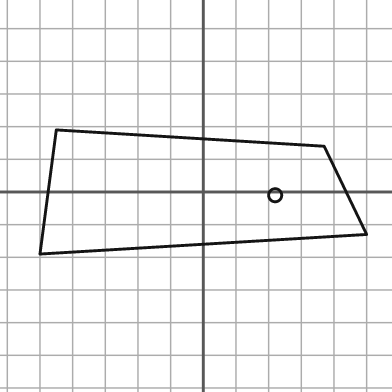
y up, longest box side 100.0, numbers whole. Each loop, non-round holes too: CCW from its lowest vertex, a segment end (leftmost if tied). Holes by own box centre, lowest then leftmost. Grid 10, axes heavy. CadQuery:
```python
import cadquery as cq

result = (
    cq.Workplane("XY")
    .moveTo(-50.0, -19.0)
    .lineTo(50.0, -13.0)
    .lineTo(37.0, 14.0)
    .lineTo(-45.0, 19.0)
    .close()
    .moveTo(22.0, -1.0)
    .circle(2.0)
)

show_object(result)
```